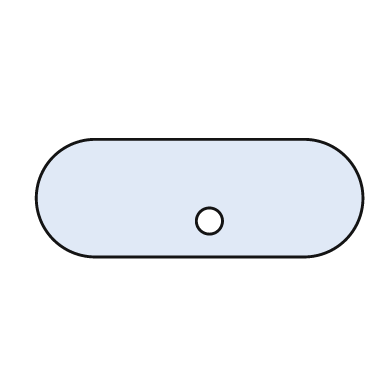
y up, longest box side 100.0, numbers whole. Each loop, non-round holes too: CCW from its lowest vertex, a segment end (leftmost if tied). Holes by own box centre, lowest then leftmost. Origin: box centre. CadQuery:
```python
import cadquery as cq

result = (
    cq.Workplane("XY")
    .moveTo(-32.0, -18.0)
    .lineTo(32.0, -18.0)
    .threePointArc((50.0, 0.0), (32.0, 18.0))
    .lineTo(-32.0, 18.0)
    .threePointArc((-50.0, 0.0), (-32.0, -18.0))
    .close()
    .moveTo(3.0, -7.0)
    .circle(4.0)
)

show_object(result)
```